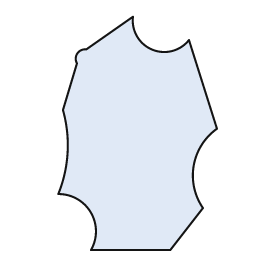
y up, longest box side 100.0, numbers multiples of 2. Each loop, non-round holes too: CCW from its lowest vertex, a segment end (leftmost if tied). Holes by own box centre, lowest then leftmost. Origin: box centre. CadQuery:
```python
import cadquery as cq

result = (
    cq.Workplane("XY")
    .moveTo(-20.0, -50.0)
    .lineTo(14.0, -50.0)
    .lineTo(28.0, -32.0)
    .threePointArc((24.0, -14.0), (34.0, 2.0))
    .lineTo(22.0, 40.0)
    .threePointArc((6.0, 36.0), (-2.0, 50.0))
    .lineTo(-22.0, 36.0)
    .threePointArc((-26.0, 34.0), (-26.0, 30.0))
    .lineTo(-32.0, 10.0)
    .threePointArc((-30.0, -8.0), (-34.0, -26.0))
    .threePointArc((-20.0, -34.0), (-20.0, -50.0))
    .close()
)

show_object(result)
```